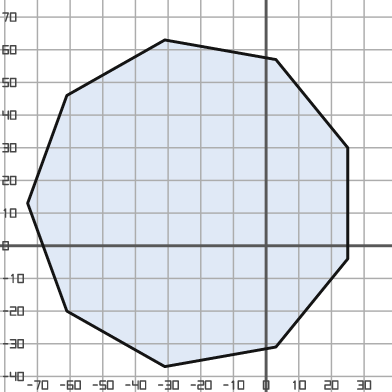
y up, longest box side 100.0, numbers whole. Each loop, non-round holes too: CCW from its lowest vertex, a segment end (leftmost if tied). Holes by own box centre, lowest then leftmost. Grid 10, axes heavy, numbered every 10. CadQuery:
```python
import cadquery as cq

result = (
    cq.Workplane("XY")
    .moveTo(-31.0, -37.0)
    .lineTo(3.0, -31.0)
    .lineTo(25.0, -4.0)
    .lineTo(25.0, 30.0)
    .lineTo(3.0, 57.0)
    .lineTo(-31.0, 63.0)
    .lineTo(-61.0, 46.0)
    .lineTo(-73.0, 13.0)
    .lineTo(-61.0, -20.0)
    .close()
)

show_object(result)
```